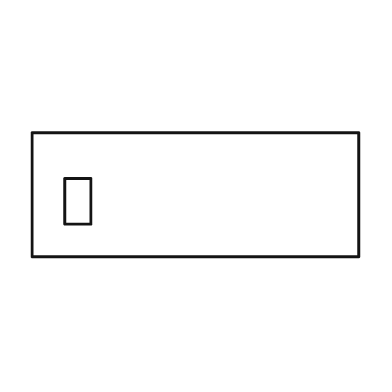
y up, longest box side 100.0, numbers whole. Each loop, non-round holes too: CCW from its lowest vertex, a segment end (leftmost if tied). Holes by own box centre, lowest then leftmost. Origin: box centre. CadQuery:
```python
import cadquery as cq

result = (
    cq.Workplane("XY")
    .moveTo(-50.0, -19.0)
    .lineTo(50.0, -19.0)
    .lineTo(50.0, 19.0)
    .lineTo(-50.0, 19.0)
    .close()
    .moveTo(-40.0, -9.0)
    .lineTo(-32.0, -9.0)
    .lineTo(-32.0, 5.0)
    .lineTo(-40.0, 5.0)
    .close()
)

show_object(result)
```